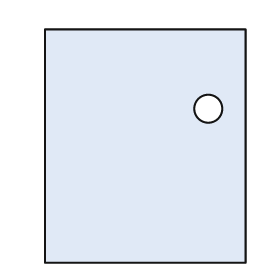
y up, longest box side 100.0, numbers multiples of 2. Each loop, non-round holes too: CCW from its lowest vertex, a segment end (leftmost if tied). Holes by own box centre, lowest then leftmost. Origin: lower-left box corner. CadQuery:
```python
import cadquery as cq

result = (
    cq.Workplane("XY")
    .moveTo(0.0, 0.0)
    .lineTo(86.0, 0.0)
    .lineTo(86.0, 100.0)
    .lineTo(0.0, 100.0)
    .close()
    .moveTo(70.0, 66.0)
    .circle(6.0)
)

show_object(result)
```